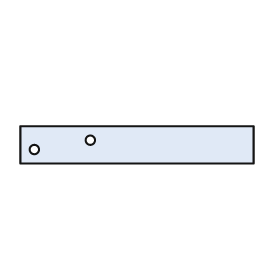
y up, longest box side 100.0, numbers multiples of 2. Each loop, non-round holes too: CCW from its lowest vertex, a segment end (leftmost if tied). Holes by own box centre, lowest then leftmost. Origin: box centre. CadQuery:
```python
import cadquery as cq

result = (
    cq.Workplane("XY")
    .moveTo(-50.0, -8.0)
    .lineTo(50.0, -8.0)
    .lineTo(50.0, 8.0)
    .lineTo(-50.0, 8.0)
    .close()
    .moveTo(-44.0, -2.0)
    .circle(2.0)
    .moveTo(-20.0, 2.0)
    .circle(2.0)
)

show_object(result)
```